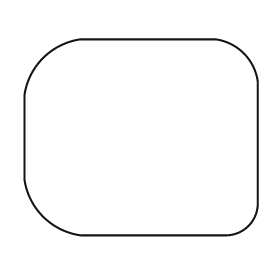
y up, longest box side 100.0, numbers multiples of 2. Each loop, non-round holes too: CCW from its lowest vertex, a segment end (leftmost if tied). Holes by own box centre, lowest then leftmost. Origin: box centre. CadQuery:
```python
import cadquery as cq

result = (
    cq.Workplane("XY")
    .moveTo(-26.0, -42.0)
    .lineTo(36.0, -42.0)
    .threePointArc((46.0, -38.0), (50.0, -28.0))
    .lineTo(50.0, 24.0)
    .threePointArc((44.0, 36.0), (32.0, 42.0))
    .lineTo(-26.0, 42.0)
    .threePointArc((-42.0, 34.0), (-50.0, 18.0))
    .lineTo(-50.0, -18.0)
    .threePointArc((-42.0, -34.0), (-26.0, -42.0))
    .close()
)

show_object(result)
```